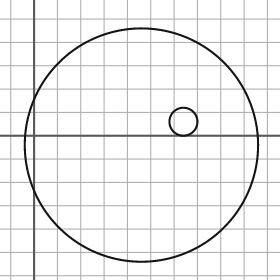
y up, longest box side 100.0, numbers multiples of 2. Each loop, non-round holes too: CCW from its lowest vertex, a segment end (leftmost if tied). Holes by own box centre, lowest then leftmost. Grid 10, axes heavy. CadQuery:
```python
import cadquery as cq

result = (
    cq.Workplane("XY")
    .moveTo(46.0, -4.0)
    .circle(50.0)
    .moveTo(64.0, 6.0)
    .circle(6.0)
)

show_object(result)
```